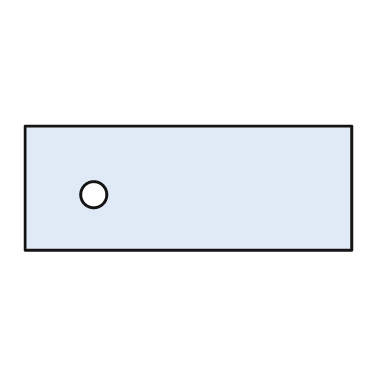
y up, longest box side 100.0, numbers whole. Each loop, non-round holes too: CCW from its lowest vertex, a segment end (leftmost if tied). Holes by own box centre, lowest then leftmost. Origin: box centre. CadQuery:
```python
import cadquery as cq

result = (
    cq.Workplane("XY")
    .moveTo(-50.0, -19.0)
    .lineTo(50.0, -19.0)
    .lineTo(50.0, 19.0)
    .lineTo(-50.0, 19.0)
    .close()
    .moveTo(-29.0, -2.0)
    .circle(4.0)
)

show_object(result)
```